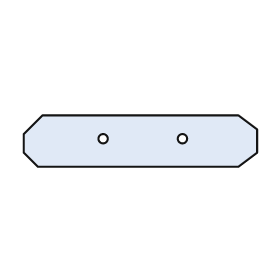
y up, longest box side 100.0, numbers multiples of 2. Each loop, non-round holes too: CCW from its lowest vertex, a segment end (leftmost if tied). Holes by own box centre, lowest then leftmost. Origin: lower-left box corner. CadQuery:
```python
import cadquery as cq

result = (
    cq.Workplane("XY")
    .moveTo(6.0, 0.0)
    .lineTo(92.0, 0.0)
    .lineTo(100.0, 6.0)
    .lineTo(100.0, 16.0)
    .lineTo(92.0, 22.0)
    .lineTo(8.0, 22.0)
    .lineTo(0.0, 14.0)
    .lineTo(0.0, 6.0)
    .close()
    .moveTo(34.0, 12.0)
    .circle(2.0)
    .moveTo(68.0, 12.0)
    .circle(2.0)
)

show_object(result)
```